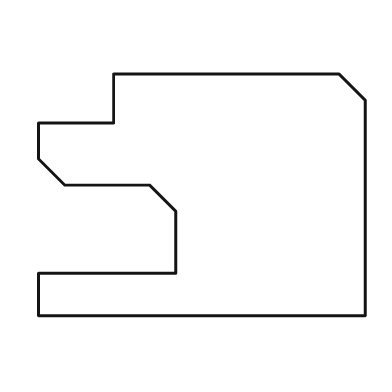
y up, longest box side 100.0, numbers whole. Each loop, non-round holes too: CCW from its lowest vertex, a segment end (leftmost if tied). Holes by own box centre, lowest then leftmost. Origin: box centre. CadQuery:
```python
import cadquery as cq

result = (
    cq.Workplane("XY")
    .moveTo(-50.0, -37.0)
    .lineTo(50.0, -37.0)
    .lineTo(50.0, 29.0)
    .lineTo(42.0, 37.0)
    .lineTo(-27.0, 37.0)
    .lineTo(-27.0, 22.0)
    .lineTo(-50.0, 22.0)
    .lineTo(-50.0, 11.0)
    .lineTo(-42.0, 3.0)
    .lineTo(-16.0, 3.0)
    .lineTo(-8.0, -5.0)
    .lineTo(-8.0, -24.0)
    .lineTo(-50.0, -24.0)
    .close()
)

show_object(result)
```